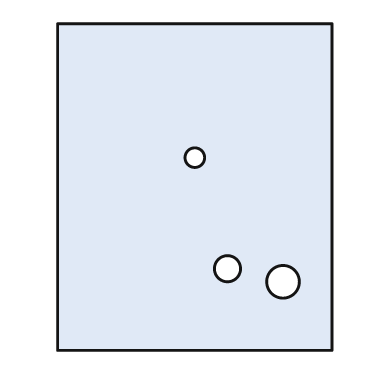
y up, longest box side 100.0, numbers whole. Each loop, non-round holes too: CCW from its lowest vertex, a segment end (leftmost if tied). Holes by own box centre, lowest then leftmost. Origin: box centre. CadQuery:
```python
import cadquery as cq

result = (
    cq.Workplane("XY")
    .moveTo(-42.0, -50.0)
    .lineTo(42.0, -50.0)
    .lineTo(42.0, 50.0)
    .lineTo(-42.0, 50.0)
    .close()
    .moveTo(27.0, -29.0)
    .circle(5.0)
    .moveTo(10.0, -25.0)
    .circle(4.0)
    .moveTo(0.0, 9.0)
    .circle(3.0)
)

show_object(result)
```